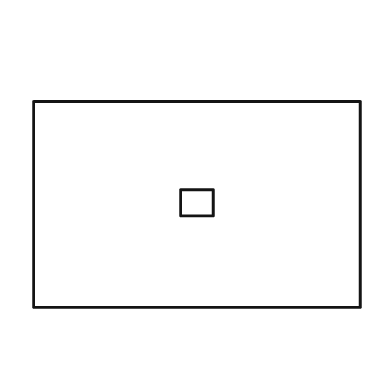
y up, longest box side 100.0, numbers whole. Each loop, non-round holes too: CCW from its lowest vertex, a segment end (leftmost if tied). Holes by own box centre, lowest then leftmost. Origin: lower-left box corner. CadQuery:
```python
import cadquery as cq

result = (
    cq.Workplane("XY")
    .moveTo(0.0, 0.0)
    .lineTo(100.0, 0.0)
    .lineTo(100.0, 63.0)
    .lineTo(0.0, 63.0)
    .close()
    .moveTo(45.0, 28.0)
    .lineTo(55.0, 28.0)
    .lineTo(55.0, 36.0)
    .lineTo(45.0, 36.0)
    .close()
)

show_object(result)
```